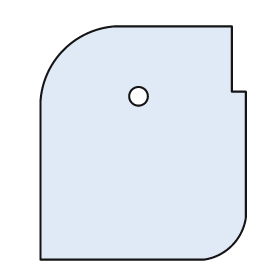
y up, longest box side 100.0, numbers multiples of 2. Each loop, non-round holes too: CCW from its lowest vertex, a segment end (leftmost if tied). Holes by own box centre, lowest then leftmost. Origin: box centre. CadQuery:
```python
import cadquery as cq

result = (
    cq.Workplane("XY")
    .moveTo(-44.0, -50.0)
    .lineTo(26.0, -50.0)
    .threePointArc((38.0, -44.0), (44.0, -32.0))
    .lineTo(44.0, 22.0)
    .lineTo(38.0, 22.0)
    .lineTo(38.0, 50.0)
    .lineTo(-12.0, 50.0)
    .threePointArc((-34.0, 40.0), (-44.0, 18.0))
    .close()
    .moveTo(-2.0, 20.0)
    .circle(4.0)
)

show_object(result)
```